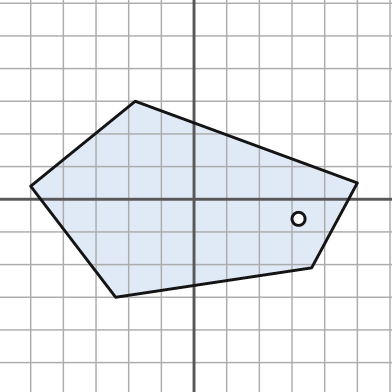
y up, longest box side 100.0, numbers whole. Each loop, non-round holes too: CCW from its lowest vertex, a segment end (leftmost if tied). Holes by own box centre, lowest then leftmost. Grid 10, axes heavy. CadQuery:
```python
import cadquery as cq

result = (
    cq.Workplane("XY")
    .moveTo(-24.0, -30.0)
    .lineTo(36.0, -21.0)
    .lineTo(50.0, 5.0)
    .lineTo(-18.0, 30.0)
    .lineTo(-50.0, 4.0)
    .close()
    .moveTo(32.0, -6.0)
    .circle(2.0)
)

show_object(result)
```